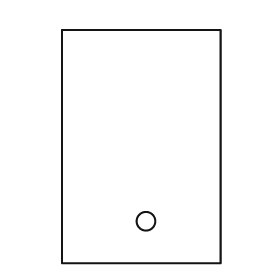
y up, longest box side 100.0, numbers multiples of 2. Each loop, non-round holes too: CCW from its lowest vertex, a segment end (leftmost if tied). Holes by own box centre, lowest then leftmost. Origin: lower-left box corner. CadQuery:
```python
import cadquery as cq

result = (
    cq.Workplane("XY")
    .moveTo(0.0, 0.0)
    .lineTo(68.0, 0.0)
    .lineTo(68.0, 100.0)
    .lineTo(0.0, 100.0)
    .close()
    .moveTo(36.0, 18.0)
    .circle(4.0)
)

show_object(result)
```